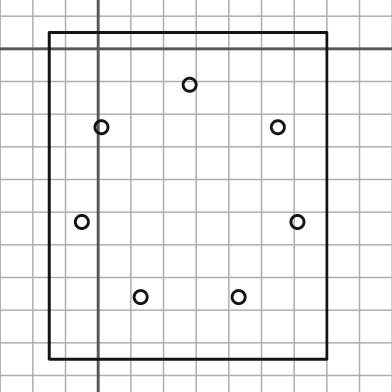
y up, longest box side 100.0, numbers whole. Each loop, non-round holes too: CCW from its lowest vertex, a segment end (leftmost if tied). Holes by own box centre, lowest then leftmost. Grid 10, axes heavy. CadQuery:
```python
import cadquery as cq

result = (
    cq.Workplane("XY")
    .moveTo(-15.0, -95.0)
    .lineTo(70.0, -95.0)
    .lineTo(70.0, 5.0)
    .lineTo(-15.0, 5.0)
    .close()
    .moveTo(13.0, -76.0)
    .circle(2.0)
    .moveTo(43.0, -76.0)
    .circle(2.0)
    .moveTo(-5.0, -53.0)
    .circle(2.0)
    .moveTo(61.0, -53.0)
    .circle(2.0)
    .moveTo(1.0, -24.0)
    .circle(2.0)
    .moveTo(55.0, -24.0)
    .circle(2.0)
    .moveTo(28.0, -11.0)
    .circle(2.0)
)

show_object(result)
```